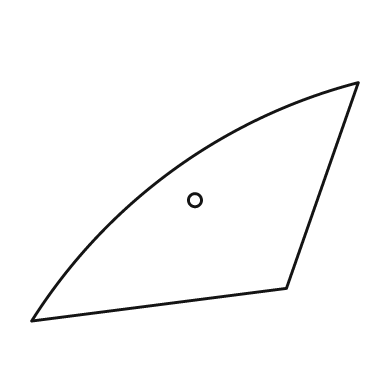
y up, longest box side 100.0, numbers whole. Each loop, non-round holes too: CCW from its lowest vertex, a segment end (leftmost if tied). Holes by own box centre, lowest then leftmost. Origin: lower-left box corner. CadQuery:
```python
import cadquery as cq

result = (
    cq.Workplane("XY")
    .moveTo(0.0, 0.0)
    .lineTo(78.0, 10.0)
    .lineTo(100.0, 73.0)
    .threePointArc((43.0, 46.0), (0.0, 0.0))
    .close()
    .moveTo(50.0, 37.0)
    .circle(2.0)
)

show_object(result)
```